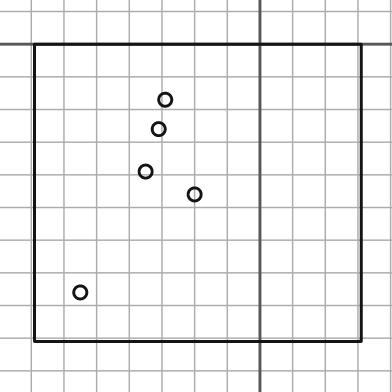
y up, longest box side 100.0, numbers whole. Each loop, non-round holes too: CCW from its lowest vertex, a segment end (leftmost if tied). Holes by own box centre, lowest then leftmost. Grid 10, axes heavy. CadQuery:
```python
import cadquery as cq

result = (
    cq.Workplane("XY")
    .moveTo(-69.0, -91.0)
    .lineTo(31.0, -91.0)
    .lineTo(31.0, 0.0)
    .lineTo(-69.0, 0.0)
    .close()
    .moveTo(-55.0, -76.0)
    .circle(2.0)
    .moveTo(-20.0, -46.0)
    .circle(2.0)
    .moveTo(-35.0, -39.0)
    .circle(2.0)
    .moveTo(-31.0, -26.0)
    .circle(2.0)
    .moveTo(-29.0, -17.0)
    .circle(2.0)
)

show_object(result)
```